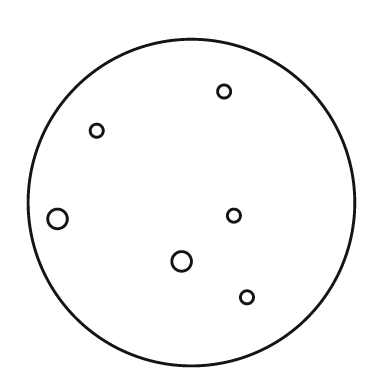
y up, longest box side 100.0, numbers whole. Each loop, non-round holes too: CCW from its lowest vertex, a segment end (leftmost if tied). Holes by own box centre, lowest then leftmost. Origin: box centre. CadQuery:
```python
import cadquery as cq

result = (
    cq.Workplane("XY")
    .moveTo(0.0, 0.0)
    .circle(50.0)
    .moveTo(17.0, -29.0)
    .circle(2.0)
    .moveTo(-3.0, -18.0)
    .circle(3.0)
    .moveTo(-41.0, -5.0)
    .circle(3.0)
    .moveTo(13.0, -4.0)
    .circle(2.0)
    .moveTo(-29.0, 22.0)
    .circle(2.0)
    .moveTo(10.0, 34.0)
    .circle(2.0)
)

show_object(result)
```